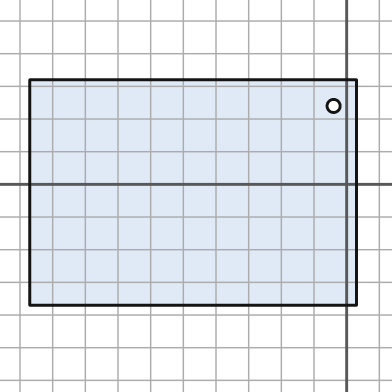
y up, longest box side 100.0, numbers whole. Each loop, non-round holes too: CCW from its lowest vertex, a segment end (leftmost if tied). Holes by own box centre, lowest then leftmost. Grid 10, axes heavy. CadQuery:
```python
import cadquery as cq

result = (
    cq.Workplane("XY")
    .moveTo(-97.0, -37.0)
    .lineTo(3.0, -37.0)
    .lineTo(3.0, 32.0)
    .lineTo(-97.0, 32.0)
    .close()
    .moveTo(-4.0, 24.0)
    .circle(2.0)
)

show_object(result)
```